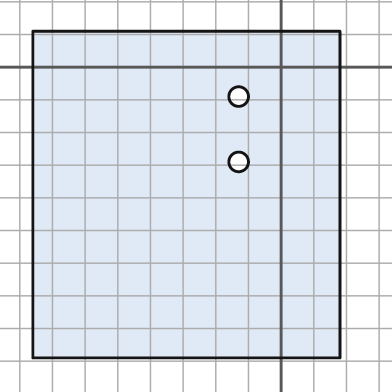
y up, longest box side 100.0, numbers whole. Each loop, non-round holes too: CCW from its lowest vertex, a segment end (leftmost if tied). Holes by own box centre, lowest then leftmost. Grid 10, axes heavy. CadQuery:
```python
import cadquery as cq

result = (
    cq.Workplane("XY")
    .moveTo(-76.0, -89.0)
    .lineTo(18.0, -89.0)
    .lineTo(18.0, 11.0)
    .lineTo(-76.0, 11.0)
    .close()
    .moveTo(-13.0, -29.0)
    .circle(3.0)
    .moveTo(-13.0, -9.0)
    .circle(3.0)
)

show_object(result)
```